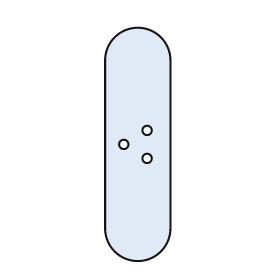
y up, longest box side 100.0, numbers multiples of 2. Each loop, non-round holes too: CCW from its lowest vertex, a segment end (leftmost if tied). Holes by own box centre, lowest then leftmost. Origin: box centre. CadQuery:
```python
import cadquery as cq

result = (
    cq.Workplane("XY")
    .moveTo(-14.0, -36.0)
    .threePointArc((0.0, -50.0), (14.0, -36.0))
    .lineTo(14.0, 36.0)
    .threePointArc((0.0, 50.0), (-14.0, 36.0))
    .close()
    .moveTo(4.0, -6.0)
    .circle(2.0)
    .moveTo(-6.0, 0.0)
    .circle(2.0)
    .moveTo(4.0, 6.0)
    .circle(2.0)
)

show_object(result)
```